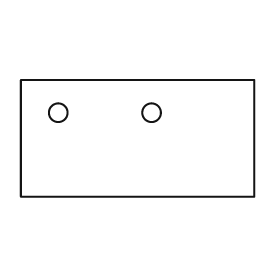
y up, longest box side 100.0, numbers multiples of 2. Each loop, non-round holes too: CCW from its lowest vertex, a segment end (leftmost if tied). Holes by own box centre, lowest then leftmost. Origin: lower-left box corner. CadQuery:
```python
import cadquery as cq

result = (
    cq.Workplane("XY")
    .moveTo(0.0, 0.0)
    .lineTo(100.0, 0.0)
    .lineTo(100.0, 50.0)
    .lineTo(0.0, 50.0)
    .close()
    .moveTo(16.0, 36.0)
    .circle(4.0)
    .moveTo(56.0, 36.0)
    .circle(4.0)
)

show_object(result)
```